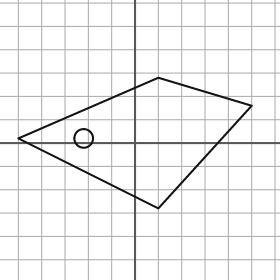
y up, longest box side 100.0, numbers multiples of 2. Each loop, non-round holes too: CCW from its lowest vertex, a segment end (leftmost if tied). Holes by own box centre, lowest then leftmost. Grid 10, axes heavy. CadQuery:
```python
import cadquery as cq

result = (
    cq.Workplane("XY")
    .moveTo(10.0, -28.0)
    .lineTo(50.0, 16.0)
    .lineTo(10.0, 28.0)
    .lineTo(-50.0, 2.0)
    .close()
    .moveTo(-22.0, 2.0)
    .circle(4.0)
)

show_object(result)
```